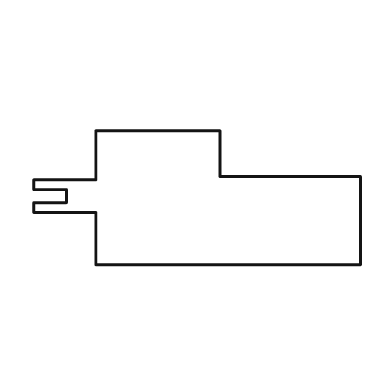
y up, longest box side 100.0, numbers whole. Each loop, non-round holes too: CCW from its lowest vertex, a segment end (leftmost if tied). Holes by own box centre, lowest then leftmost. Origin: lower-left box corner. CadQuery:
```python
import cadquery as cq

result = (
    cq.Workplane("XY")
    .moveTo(19.0, 0.0)
    .lineTo(100.0, 0.0)
    .lineTo(100.0, 27.0)
    .lineTo(57.0, 27.0)
    .lineTo(57.0, 41.0)
    .lineTo(19.0, 41.0)
    .lineTo(19.0, 26.0)
    .lineTo(0.0, 26.0)
    .lineTo(0.0, 23.0)
    .lineTo(10.0, 23.0)
    .lineTo(10.0, 19.0)
    .lineTo(0.0, 19.0)
    .lineTo(0.0, 16.0)
    .lineTo(19.0, 16.0)
    .close()
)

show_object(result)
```